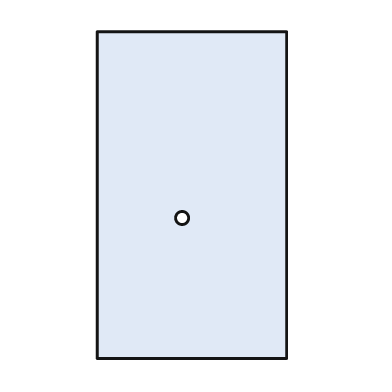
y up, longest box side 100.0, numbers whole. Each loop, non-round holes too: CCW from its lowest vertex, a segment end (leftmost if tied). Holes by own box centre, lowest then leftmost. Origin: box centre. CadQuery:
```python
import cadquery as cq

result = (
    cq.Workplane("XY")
    .moveTo(-29.0, -50.0)
    .lineTo(29.0, -50.0)
    .lineTo(29.0, 50.0)
    .lineTo(-29.0, 50.0)
    .close()
    .moveTo(-3.0, -7.0)
    .circle(2.0)
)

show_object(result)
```